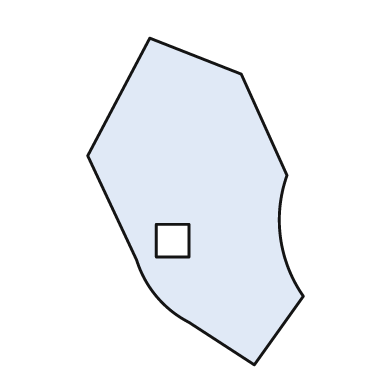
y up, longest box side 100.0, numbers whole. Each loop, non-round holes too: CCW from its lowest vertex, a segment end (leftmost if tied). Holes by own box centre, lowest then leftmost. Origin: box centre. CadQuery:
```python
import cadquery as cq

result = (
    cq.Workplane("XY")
    .moveTo(18.0, -50.0)
    .lineTo(33.0, -29.0)
    .threePointArc((26.0, -11.0), (28.0, 8.0))
    .lineTo(14.0, 39.0)
    .lineTo(-14.0, 50.0)
    .lineTo(-33.0, 14.0)
    .lineTo(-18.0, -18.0)
    .threePointArc((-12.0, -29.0), (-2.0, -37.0))
    .close()
    .moveTo(-12.0, -17.0)
    .lineTo(-2.0, -17.0)
    .lineTo(-2.0, -7.0)
    .lineTo(-12.0, -7.0)
    .close()
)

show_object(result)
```